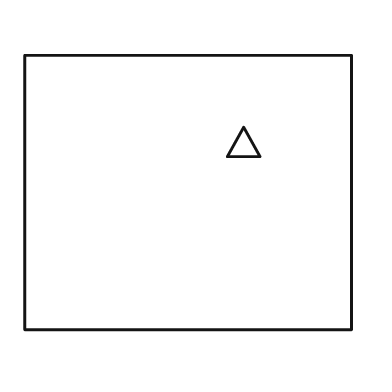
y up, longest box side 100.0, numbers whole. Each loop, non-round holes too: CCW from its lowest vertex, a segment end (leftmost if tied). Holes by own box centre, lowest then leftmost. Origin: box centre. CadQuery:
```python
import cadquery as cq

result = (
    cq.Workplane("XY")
    .moveTo(-50.0, -42.0)
    .lineTo(50.0, -42.0)
    .lineTo(50.0, 42.0)
    .lineTo(-50.0, 42.0)
    .close()
    .moveTo(12.0, 11.0)
    .lineTo(22.0, 11.0)
    .lineTo(17.0, 20.0)
    .close()
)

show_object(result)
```